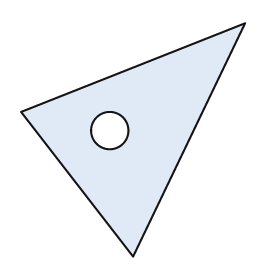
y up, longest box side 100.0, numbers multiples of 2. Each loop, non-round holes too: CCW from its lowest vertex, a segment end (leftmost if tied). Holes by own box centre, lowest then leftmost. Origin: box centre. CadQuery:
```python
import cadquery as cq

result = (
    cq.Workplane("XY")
    .moveTo(0.0, -50.0)
    .lineTo(48.0, 50.0)
    .lineTo(-48.0, 12.0)
    .close()
    .moveTo(-10.0, 4.0)
    .circle(8.0)
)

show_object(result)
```